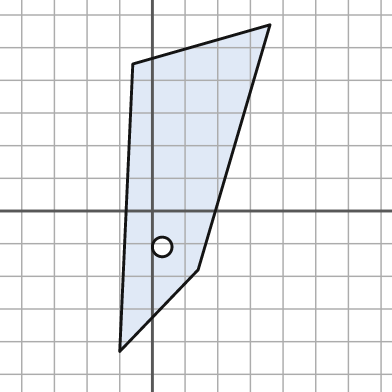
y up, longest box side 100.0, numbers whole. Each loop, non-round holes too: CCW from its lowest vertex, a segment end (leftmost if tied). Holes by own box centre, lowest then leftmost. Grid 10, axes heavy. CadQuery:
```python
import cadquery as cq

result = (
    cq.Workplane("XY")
    .moveTo(-10.0, -43.0)
    .lineTo(14.0, -18.0)
    .lineTo(36.0, 57.0)
    .lineTo(-6.0, 45.0)
    .close()
    .moveTo(3.0, -11.0)
    .circle(3.0)
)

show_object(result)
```